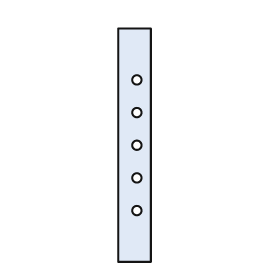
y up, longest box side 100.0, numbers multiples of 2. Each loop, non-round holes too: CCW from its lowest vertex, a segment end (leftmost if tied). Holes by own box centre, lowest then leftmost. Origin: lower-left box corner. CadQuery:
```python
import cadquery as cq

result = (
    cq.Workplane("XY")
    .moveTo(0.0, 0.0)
    .lineTo(14.0, 0.0)
    .lineTo(14.0, 100.0)
    .lineTo(0.0, 100.0)
    .close()
    .moveTo(8.0, 22.0)
    .circle(2.0)
    .moveTo(8.0, 36.0)
    .circle(2.0)
    .moveTo(8.0, 50.0)
    .circle(2.0)
    .moveTo(8.0, 64.0)
    .circle(2.0)
    .moveTo(8.0, 78.0)
    .circle(2.0)
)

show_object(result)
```